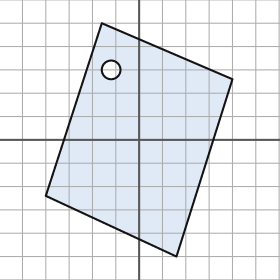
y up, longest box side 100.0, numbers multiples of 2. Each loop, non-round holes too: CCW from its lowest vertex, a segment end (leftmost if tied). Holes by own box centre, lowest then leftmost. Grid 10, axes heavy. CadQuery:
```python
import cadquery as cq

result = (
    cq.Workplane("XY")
    .moveTo(16.0, -50.0)
    .lineTo(40.0, 26.0)
    .lineTo(-16.0, 50.0)
    .lineTo(-40.0, -24.0)
    .close()
    .moveTo(-12.0, 30.0)
    .circle(4.0)
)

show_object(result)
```